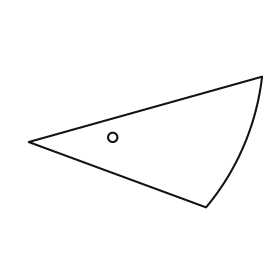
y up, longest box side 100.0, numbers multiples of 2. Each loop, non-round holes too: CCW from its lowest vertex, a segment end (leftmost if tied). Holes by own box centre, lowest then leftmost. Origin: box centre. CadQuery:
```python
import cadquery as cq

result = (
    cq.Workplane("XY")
    .moveTo(26.0, -28.0)
    .threePointArc((42.0, -2.0), (50.0, 28.0))
    .lineTo(-50.0, 0.0)
    .close()
    .moveTo(-14.0, 2.0)
    .circle(2.0)
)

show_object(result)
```